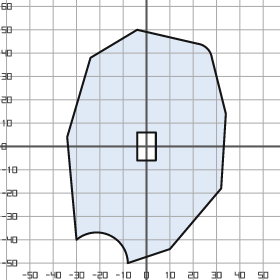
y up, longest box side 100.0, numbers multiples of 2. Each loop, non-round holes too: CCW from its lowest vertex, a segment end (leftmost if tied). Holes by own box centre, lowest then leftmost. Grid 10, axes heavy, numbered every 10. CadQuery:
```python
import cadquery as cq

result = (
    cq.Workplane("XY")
    .moveTo(-8.0, -50.0)
    .lineTo(10.0, -44.0)
    .lineTo(32.0, -18.0)
    .lineTo(34.0, 14.0)
    .lineTo(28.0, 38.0)
    .threePointArc((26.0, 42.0), (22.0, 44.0))
    .lineTo(-4.0, 50.0)
    .lineTo(-24.0, 38.0)
    .lineTo(-34.0, 4.0)
    .lineTo(-30.0, -40.0)
    .threePointArc((-16.0, -38.0), (-8.0, -50.0))
    .close()
    .moveTo(-4.0, -6.0)
    .lineTo(4.0, -6.0)
    .lineTo(4.0, 6.0)
    .lineTo(-4.0, 6.0)
    .close()
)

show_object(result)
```